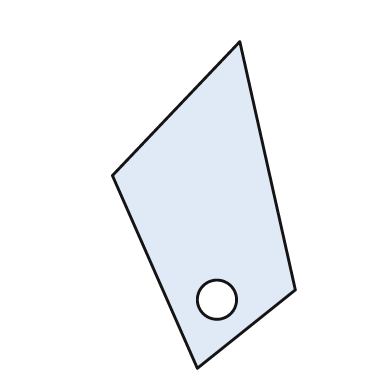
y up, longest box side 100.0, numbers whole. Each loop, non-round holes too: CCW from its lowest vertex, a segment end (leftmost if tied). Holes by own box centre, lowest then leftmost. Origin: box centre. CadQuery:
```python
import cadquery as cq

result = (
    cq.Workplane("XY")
    .moveTo(-2.0, -50.0)
    .lineTo(28.0, -26.0)
    .lineTo(11.0, 50.0)
    .lineTo(-28.0, 9.0)
    .close()
    .moveTo(4.0, -29.0)
    .circle(6.0)
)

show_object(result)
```